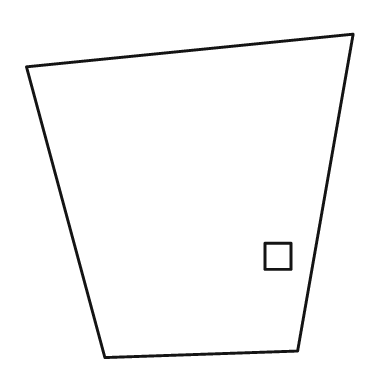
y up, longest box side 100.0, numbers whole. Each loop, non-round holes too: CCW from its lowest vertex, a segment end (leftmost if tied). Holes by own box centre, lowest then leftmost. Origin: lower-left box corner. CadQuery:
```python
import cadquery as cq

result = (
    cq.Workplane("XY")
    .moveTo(24.0, 0.0)
    .lineTo(83.0, 2.0)
    .lineTo(100.0, 99.0)
    .lineTo(0.0, 89.0)
    .close()
    .moveTo(73.0, 27.0)
    .lineTo(81.0, 27.0)
    .lineTo(81.0, 35.0)
    .lineTo(73.0, 35.0)
    .close()
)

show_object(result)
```